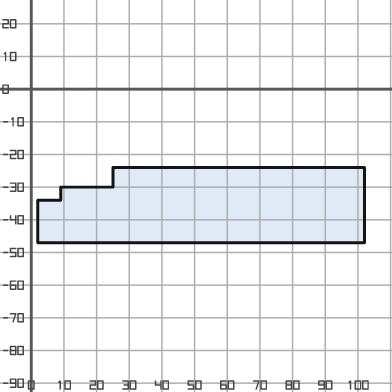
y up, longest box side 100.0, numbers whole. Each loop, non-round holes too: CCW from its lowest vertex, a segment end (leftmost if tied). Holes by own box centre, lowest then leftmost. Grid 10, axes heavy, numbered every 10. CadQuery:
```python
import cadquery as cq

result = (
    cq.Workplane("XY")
    .moveTo(2.0, -47.0)
    .lineTo(102.0, -47.0)
    .lineTo(102.0, -24.0)
    .lineTo(25.0, -24.0)
    .lineTo(25.0, -30.0)
    .lineTo(9.0, -30.0)
    .lineTo(9.0, -34.0)
    .lineTo(2.0, -34.0)
    .close()
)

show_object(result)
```